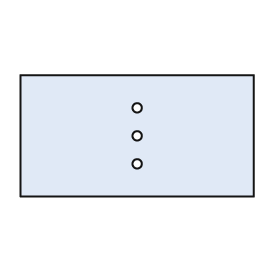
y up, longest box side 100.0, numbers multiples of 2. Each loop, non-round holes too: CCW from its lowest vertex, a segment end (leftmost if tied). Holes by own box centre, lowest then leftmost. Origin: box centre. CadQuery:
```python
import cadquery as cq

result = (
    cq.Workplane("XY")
    .moveTo(-50.0, -26.0)
    .lineTo(50.0, -26.0)
    .lineTo(50.0, 26.0)
    .lineTo(-50.0, 26.0)
    .close()
    .moveTo(0.0, -12.0)
    .circle(2.0)
    .moveTo(0.0, 0.0)
    .circle(2.0)
    .moveTo(0.0, 12.0)
    .circle(2.0)
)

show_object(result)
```